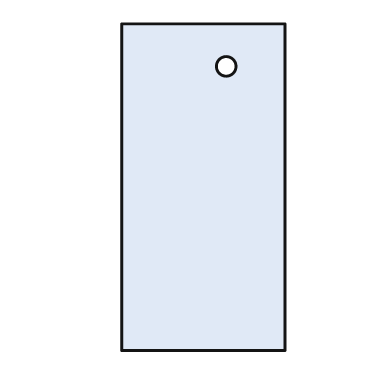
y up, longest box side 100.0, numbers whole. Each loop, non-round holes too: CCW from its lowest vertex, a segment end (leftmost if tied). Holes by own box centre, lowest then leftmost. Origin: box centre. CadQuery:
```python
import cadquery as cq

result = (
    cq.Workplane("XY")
    .moveTo(-25.0, -50.0)
    .lineTo(25.0, -50.0)
    .lineTo(25.0, 50.0)
    .lineTo(-25.0, 50.0)
    .close()
    .moveTo(7.0, 37.0)
    .circle(3.0)
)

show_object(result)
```